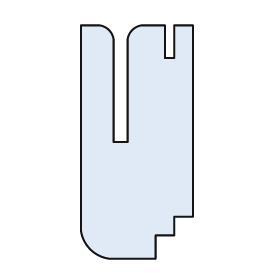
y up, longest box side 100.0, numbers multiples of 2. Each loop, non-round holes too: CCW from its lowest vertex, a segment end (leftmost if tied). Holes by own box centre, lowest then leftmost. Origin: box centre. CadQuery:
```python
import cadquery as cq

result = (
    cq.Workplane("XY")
    .moveTo(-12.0, -50.0)
    .lineTo(8.0, -50.0)
    .lineTo(8.0, -40.0)
    .lineTo(16.0, -40.0)
    .lineTo(16.0, -32.0)
    .lineTo(24.0, -32.0)
    .lineTo(24.0, 50.0)
    .lineTo(16.0, 50.0)
    .lineTo(16.0, 36.0)
    .lineTo(12.0, 36.0)
    .lineTo(12.0, 50.0)
    .lineTo(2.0, 50.0)
    .threePointArc((-2.0, 48.0), (-4.0, 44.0))
    .lineTo(-4.0, 0.0)
    .lineTo(-10.0, 0.0)
    .lineTo(-10.0, 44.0)
    .threePointArc((-12.0, 48.0), (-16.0, 50.0))
    .lineTo(-24.0, 50.0)
    .lineTo(-24.0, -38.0)
    .threePointArc((-20.0, -46.0), (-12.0, -50.0))
    .close()
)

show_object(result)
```